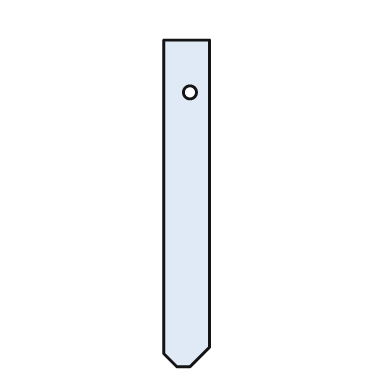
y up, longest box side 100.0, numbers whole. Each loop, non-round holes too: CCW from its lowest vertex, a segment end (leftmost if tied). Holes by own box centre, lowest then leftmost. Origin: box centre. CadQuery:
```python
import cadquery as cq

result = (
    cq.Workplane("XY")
    .moveTo(-3.0, -50.0)
    .lineTo(1.0, -50.0)
    .lineTo(7.0, -44.0)
    .lineTo(7.0, 50.0)
    .lineTo(-7.0, 50.0)
    .lineTo(-7.0, -46.0)
    .close()
    .moveTo(1.0, 34.0)
    .circle(2.0)
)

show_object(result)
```